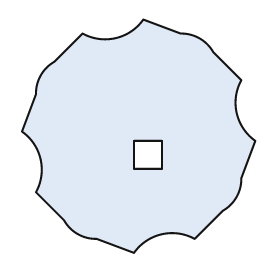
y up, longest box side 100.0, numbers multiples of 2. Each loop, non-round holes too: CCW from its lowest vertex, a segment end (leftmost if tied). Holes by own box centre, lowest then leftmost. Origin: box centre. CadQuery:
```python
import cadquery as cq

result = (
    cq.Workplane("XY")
    .moveTo(-2.0, -50.0)
    .threePointArc((10.0, -42.0), (24.0, -44.0))
    .lineTo(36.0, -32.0)
    .threePointArc((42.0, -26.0), (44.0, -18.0))
    .lineTo(50.0, -2.0)
    .threePointArc((42.0, 10.0), (44.0, 24.0))
    .lineTo(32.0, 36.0)
    .threePointArc((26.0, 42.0), (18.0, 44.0))
    .lineTo(2.0, 50.0)
    .threePointArc((-10.0, 42.0), (-24.0, 44.0))
    .lineTo(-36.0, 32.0)
    .threePointArc((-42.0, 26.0), (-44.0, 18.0))
    .lineTo(-50.0, 2.0)
    .threePointArc((-42.0, -10.0), (-44.0, -24.0))
    .lineTo(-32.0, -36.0)
    .threePointArc((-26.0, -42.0), (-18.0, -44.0))
    .close()
    .moveTo(-2.0, -14.0)
    .lineTo(10.0, -14.0)
    .lineTo(10.0, -2.0)
    .lineTo(-2.0, -2.0)
    .close()
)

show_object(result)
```